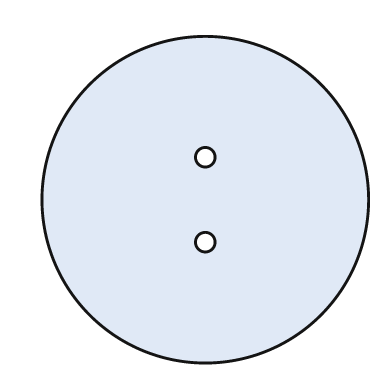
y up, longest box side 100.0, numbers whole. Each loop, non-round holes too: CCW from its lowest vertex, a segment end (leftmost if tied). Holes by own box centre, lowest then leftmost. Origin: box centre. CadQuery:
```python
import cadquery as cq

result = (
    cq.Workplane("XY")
    .moveTo(0.0, 0.0)
    .circle(50.0)
    .moveTo(0.0, -13.0)
    .circle(3.0)
    .moveTo(0.0, 13.0)
    .circle(3.0)
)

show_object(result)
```